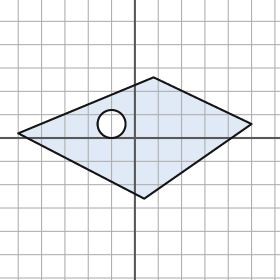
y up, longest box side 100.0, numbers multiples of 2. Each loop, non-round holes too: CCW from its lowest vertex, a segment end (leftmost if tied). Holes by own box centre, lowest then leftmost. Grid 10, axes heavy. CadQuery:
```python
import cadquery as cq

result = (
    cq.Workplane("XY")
    .moveTo(4.0, -26.0)
    .lineTo(50.0, 6.0)
    .lineTo(8.0, 26.0)
    .lineTo(-50.0, 2.0)
    .close()
    .moveTo(-10.0, 6.0)
    .circle(6.0)
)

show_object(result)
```